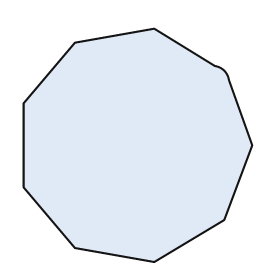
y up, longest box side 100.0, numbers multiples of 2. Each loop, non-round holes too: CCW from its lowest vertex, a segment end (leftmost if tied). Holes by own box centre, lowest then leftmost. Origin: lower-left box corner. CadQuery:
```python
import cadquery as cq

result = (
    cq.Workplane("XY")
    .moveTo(56.0, 0.0)
    .lineTo(86.0, 18.0)
    .lineTo(98.0, 50.0)
    .lineTo(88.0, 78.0)
    .threePointArc((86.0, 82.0), (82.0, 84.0))
    .lineTo(56.0, 100.0)
    .lineTo(22.0, 94.0)
    .lineTo(0.0, 68.0)
    .lineTo(0.0, 32.0)
    .lineTo(22.0, 6.0)
    .close()
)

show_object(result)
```